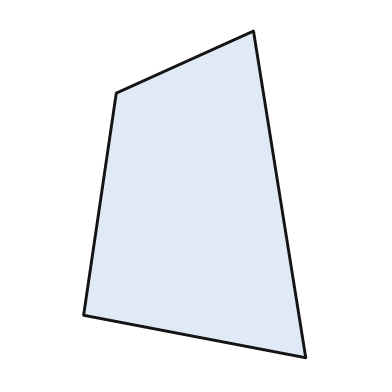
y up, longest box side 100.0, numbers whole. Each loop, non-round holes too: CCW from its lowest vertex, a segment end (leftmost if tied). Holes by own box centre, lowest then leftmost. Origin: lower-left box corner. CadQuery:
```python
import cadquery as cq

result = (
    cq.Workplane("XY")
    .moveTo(68.0, 0.0)
    .lineTo(52.0, 100.0)
    .lineTo(10.0, 81.0)
    .lineTo(0.0, 13.0)
    .close()
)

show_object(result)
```